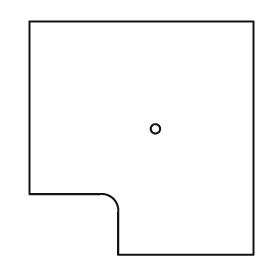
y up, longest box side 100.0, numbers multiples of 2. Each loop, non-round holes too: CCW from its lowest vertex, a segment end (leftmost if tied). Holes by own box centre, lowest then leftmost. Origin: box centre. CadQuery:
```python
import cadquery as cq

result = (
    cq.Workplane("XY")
    .moveTo(-10.0, -50.0)
    .lineTo(48.0, -50.0)
    .lineTo(48.0, 50.0)
    .lineTo(-48.0, 50.0)
    .lineTo(-48.0, -24.0)
    .lineTo(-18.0, -24.0)
    .threePointArc((-12.0, -26.0), (-10.0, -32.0))
    .close()
    .moveTo(6.0, 4.0)
    .circle(2.0)
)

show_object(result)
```